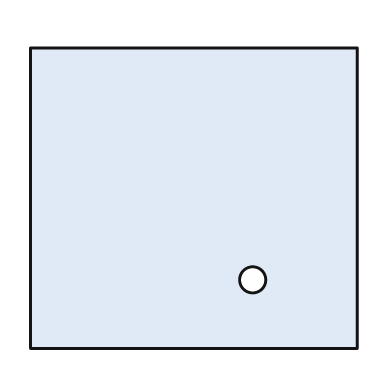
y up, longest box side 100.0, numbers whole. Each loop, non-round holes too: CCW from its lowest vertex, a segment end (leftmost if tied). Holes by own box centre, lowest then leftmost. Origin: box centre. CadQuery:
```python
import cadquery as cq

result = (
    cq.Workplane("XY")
    .moveTo(-50.0, -46.0)
    .lineTo(50.0, -46.0)
    .lineTo(50.0, 46.0)
    .lineTo(-50.0, 46.0)
    .close()
    .moveTo(18.0, -25.0)
    .circle(4.0)
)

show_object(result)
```